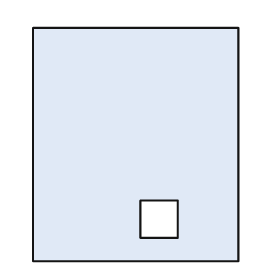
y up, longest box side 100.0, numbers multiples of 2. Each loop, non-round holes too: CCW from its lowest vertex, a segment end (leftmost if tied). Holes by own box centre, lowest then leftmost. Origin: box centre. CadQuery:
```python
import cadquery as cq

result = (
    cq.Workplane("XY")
    .moveTo(-44.0, -50.0)
    .lineTo(44.0, -50.0)
    .lineTo(44.0, 50.0)
    .lineTo(-44.0, 50.0)
    .close()
    .moveTo(2.0, -40.0)
    .lineTo(18.0, -40.0)
    .lineTo(18.0, -24.0)
    .lineTo(2.0, -24.0)
    .close()
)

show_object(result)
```